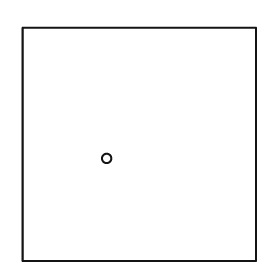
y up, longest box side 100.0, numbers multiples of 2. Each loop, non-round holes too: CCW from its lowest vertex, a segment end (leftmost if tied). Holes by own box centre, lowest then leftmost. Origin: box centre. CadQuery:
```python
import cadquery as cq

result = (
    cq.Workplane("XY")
    .moveTo(-50.0, -50.0)
    .lineTo(50.0, -50.0)
    .lineTo(50.0, 50.0)
    .lineTo(-50.0, 50.0)
    .close()
    .moveTo(-14.0, -6.0)
    .circle(2.0)
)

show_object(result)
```